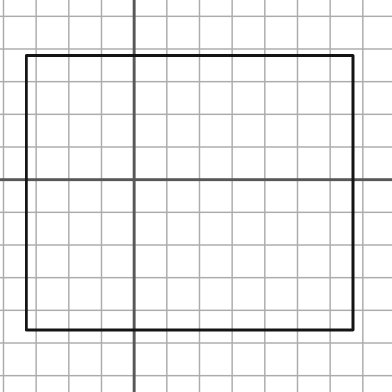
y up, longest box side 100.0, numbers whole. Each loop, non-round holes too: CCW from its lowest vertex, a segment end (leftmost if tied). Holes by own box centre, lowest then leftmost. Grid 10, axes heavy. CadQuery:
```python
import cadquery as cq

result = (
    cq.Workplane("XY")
    .moveTo(-33.0, -46.0)
    .lineTo(67.0, -46.0)
    .lineTo(67.0, 38.0)
    .lineTo(-33.0, 38.0)
    .close()
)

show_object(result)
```